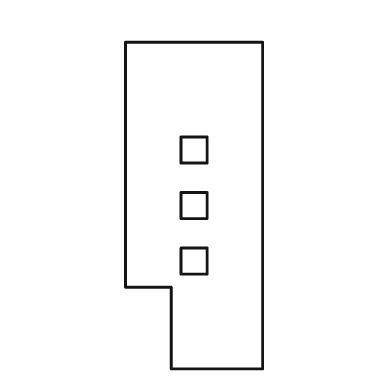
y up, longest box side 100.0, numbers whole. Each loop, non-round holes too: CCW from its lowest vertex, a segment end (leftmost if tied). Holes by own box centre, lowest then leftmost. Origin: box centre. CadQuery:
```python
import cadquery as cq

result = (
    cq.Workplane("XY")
    .moveTo(-7.0, -50.0)
    .lineTo(21.0, -50.0)
    .lineTo(21.0, 50.0)
    .lineTo(-21.0, 50.0)
    .lineTo(-21.0, -25.0)
    .lineTo(-7.0, -25.0)
    .close()
    .moveTo(-4.0, -21.0)
    .lineTo(4.0, -21.0)
    .lineTo(4.0, -13.0)
    .lineTo(-4.0, -13.0)
    .close()
    .moveTo(-4.0, -4.0)
    .lineTo(4.0, -4.0)
    .lineTo(4.0, 4.0)
    .lineTo(-4.0, 4.0)
    .close()
    .moveTo(-4.0, 13.0)
    .lineTo(4.0, 13.0)
    .lineTo(4.0, 21.0)
    .lineTo(-4.0, 21.0)
    .close()
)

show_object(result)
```